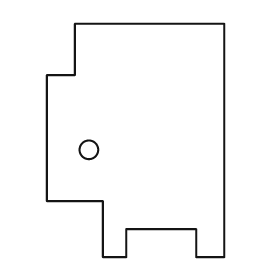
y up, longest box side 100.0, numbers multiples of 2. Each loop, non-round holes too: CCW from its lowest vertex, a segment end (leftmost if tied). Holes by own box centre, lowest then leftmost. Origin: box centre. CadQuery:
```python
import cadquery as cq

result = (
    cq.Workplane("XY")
    .moveTo(-14.0, -50.0)
    .lineTo(-4.0, -50.0)
    .lineTo(-4.0, -38.0)
    .lineTo(26.0, -38.0)
    .lineTo(26.0, -50.0)
    .lineTo(38.0, -50.0)
    .lineTo(38.0, 50.0)
    .lineTo(-26.0, 50.0)
    .lineTo(-26.0, 28.0)
    .lineTo(-38.0, 28.0)
    .lineTo(-38.0, -26.0)
    .lineTo(-14.0, -26.0)
    .close()
    .moveTo(-20.0, -4.0)
    .circle(4.0)
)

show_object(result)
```